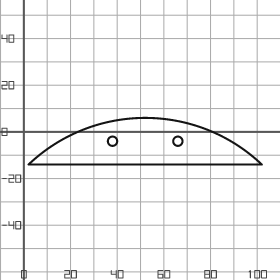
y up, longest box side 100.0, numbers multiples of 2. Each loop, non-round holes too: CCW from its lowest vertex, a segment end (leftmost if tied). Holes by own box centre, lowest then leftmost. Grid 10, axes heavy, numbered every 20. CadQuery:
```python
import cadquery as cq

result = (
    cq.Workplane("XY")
    .moveTo(2.0, -14.0)
    .lineTo(102.0, -14.0)
    .threePointArc((52.0, 6.0), (2.0, -14.0))
    .close()
    .moveTo(38.0, -4.0)
    .circle(2.0)
    .moveTo(66.0, -4.0)
    .circle(2.0)
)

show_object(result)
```